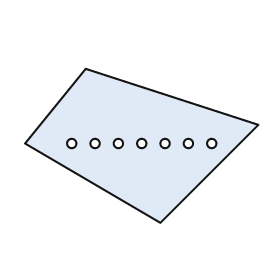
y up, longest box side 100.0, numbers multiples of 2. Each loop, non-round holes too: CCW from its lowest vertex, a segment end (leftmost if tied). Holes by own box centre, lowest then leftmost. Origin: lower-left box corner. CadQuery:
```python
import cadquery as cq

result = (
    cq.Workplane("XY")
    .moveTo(58.0, 0.0)
    .lineTo(100.0, 42.0)
    .lineTo(26.0, 66.0)
    .lineTo(0.0, 34.0)
    .close()
    .moveTo(20.0, 34.0)
    .circle(2.0)
    .moveTo(30.0, 34.0)
    .circle(2.0)
    .moveTo(40.0, 34.0)
    .circle(2.0)
    .moveTo(50.0, 34.0)
    .circle(2.0)
    .moveTo(60.0, 34.0)
    .circle(2.0)
    .moveTo(70.0, 34.0)
    .circle(2.0)
    .moveTo(80.0, 34.0)
    .circle(2.0)
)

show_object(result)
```